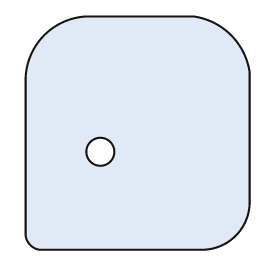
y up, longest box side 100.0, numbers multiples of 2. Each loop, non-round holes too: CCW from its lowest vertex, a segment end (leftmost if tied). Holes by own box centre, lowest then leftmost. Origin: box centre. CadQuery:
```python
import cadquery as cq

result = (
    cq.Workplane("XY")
    .moveTo(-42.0, -50.0)
    .lineTo(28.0, -50.0)
    .threePointArc((42.0, -44.0), (48.0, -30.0))
    .lineTo(48.0, 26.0)
    .threePointArc((40.0, 42.0), (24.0, 50.0))
    .lineTo(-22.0, 50.0)
    .threePointArc((-40.0, 42.0), (-48.0, 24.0))
    .lineTo(-48.0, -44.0)
    .threePointArc((-46.0, -48.0), (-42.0, -50.0))
    .close()
    .moveTo(-16.0, -8.0)
    .circle(6.0)
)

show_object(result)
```